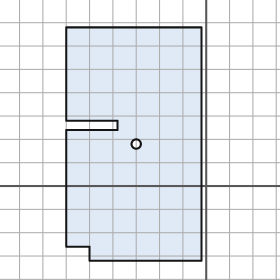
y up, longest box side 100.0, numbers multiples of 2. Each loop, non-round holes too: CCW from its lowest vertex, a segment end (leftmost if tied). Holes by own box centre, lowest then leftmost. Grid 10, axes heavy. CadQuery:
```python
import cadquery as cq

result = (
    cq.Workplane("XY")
    .moveTo(-50.0, -32.0)
    .lineTo(-2.0, -32.0)
    .lineTo(-2.0, 68.0)
    .lineTo(-60.0, 68.0)
    .lineTo(-60.0, 28.0)
    .lineTo(-38.0, 28.0)
    .lineTo(-38.0, 24.0)
    .lineTo(-60.0, 24.0)
    .lineTo(-60.0, -26.0)
    .lineTo(-50.0, -26.0)
    .close()
    .moveTo(-30.0, 18.0)
    .circle(2.0)
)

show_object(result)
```